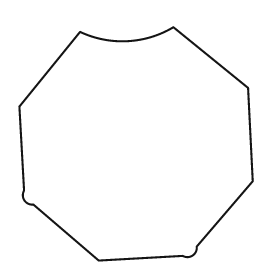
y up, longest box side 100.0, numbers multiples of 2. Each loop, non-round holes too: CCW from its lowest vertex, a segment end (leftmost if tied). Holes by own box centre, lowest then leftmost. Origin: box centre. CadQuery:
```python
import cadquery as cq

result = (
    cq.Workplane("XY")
    .moveTo(-16.0, -50.0)
    .lineTo(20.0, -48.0)
    .threePointArc((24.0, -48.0), (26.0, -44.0))
    .lineTo(50.0, -16.0)
    .lineTo(48.0, 24.0)
    .lineTo(16.0, 50.0)
    .threePointArc((-4.0, 44.0), (-24.0, 48.0))
    .lineTo(-50.0, 16.0)
    .lineTo(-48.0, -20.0)
    .threePointArc((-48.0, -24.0), (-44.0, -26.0))
    .close()
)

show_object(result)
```